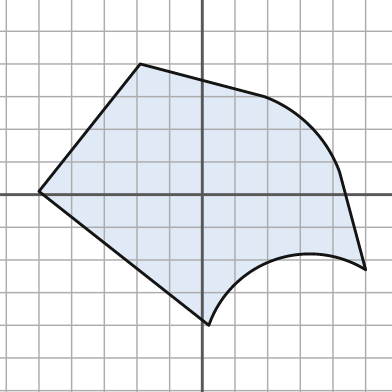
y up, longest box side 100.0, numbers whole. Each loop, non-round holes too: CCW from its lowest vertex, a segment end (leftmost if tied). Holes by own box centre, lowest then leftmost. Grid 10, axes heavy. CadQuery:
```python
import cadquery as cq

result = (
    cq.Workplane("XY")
    .moveTo(2.0, -40.0)
    .threePointArc((22.0, -20.0), (50.0, -23.0))
    .lineTo(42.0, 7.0)
    .threePointArc((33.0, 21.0), (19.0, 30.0))
    .lineTo(-19.0, 40.0)
    .lineTo(-50.0, 1.0)
    .close()
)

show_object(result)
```